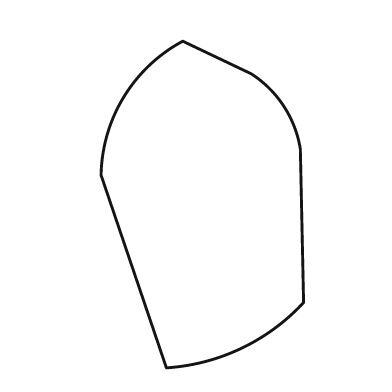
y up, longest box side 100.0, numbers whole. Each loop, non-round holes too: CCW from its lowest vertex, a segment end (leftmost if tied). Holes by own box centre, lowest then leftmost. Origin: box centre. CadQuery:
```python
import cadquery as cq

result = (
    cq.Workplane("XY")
    .moveTo(-11.0, -50.0)
    .threePointArc((12.0, -44.0), (31.0, -30.0))
    .lineTo(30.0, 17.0)
    .threePointArc((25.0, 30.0), (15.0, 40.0))
    .lineTo(-6.0, 50.0)
    .threePointArc((-24.0, 33.0), (-31.0, 9.0))
    .close()
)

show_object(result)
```